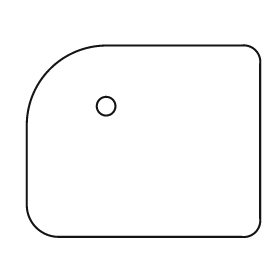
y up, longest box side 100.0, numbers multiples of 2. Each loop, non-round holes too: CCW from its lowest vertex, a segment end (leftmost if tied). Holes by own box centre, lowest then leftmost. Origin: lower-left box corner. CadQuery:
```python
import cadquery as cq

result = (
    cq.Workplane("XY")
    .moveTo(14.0, 0.0)
    .lineTo(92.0, 0.0)
    .threePointArc((98.0, 2.0), (100.0, 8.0))
    .lineTo(100.0, 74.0)
    .threePointArc((98.0, 80.0), (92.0, 82.0))
    .lineTo(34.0, 82.0)
    .threePointArc((10.0, 72.0), (0.0, 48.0))
    .lineTo(0.0, 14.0)
    .threePointArc((4.0, 4.0), (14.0, 0.0))
    .close()
    .moveTo(34.0, 56.0)
    .circle(4.0)
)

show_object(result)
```